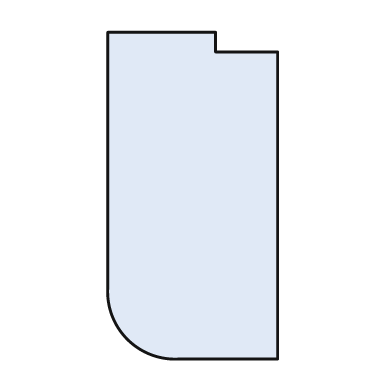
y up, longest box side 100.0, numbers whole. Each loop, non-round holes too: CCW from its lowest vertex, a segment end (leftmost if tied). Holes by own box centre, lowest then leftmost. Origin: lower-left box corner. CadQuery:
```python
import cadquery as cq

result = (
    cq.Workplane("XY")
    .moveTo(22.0, 0.0)
    .lineTo(52.0, 0.0)
    .lineTo(52.0, 94.0)
    .lineTo(33.0, 94.0)
    .lineTo(33.0, 100.0)
    .lineTo(0.0, 100.0)
    .lineTo(0.0, 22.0)
    .threePointArc((6.0, 6.0), (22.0, 0.0))
    .close()
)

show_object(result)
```